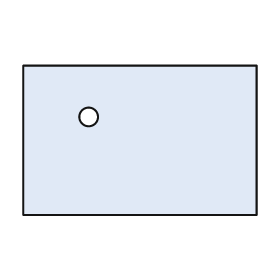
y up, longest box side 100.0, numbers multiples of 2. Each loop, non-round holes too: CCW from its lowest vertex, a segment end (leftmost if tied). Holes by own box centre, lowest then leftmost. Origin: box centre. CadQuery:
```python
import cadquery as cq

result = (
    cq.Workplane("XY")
    .moveTo(-50.0, -32.0)
    .lineTo(50.0, -32.0)
    .lineTo(50.0, 32.0)
    .lineTo(-50.0, 32.0)
    .close()
    .moveTo(-22.0, 10.0)
    .circle(4.0)
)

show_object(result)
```